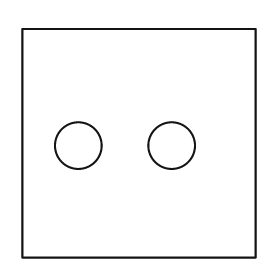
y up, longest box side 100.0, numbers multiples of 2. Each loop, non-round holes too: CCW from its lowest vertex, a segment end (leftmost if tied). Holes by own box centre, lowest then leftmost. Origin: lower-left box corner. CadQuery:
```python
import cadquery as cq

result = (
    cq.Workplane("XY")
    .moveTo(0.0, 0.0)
    .lineTo(100.0, 0.0)
    .lineTo(100.0, 98.0)
    .lineTo(0.0, 98.0)
    .close()
    .moveTo(24.0, 48.0)
    .circle(10.0)
    .moveTo(64.0, 48.0)
    .circle(10.0)
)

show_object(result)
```